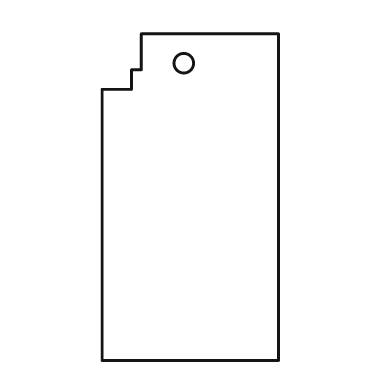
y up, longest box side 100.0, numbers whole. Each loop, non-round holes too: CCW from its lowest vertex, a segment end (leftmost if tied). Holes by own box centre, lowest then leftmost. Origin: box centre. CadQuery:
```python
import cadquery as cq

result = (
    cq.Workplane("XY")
    .moveTo(-27.0, -50.0)
    .lineTo(27.0, -50.0)
    .lineTo(27.0, 50.0)
    .lineTo(-15.0, 50.0)
    .lineTo(-15.0, 39.0)
    .lineTo(-18.0, 39.0)
    .lineTo(-18.0, 33.0)
    .lineTo(-27.0, 33.0)
    .close()
    .moveTo(-2.0, 41.0)
    .circle(3.0)
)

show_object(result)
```